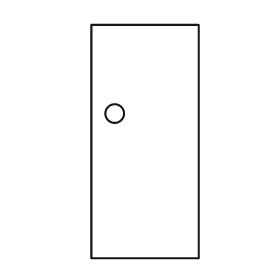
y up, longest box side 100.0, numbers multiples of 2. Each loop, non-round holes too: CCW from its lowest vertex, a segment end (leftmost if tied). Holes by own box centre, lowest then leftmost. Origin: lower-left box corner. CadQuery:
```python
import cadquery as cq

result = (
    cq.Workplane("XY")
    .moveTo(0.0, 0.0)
    .lineTo(46.0, 0.0)
    .lineTo(46.0, 100.0)
    .lineTo(0.0, 100.0)
    .close()
    .moveTo(10.0, 62.0)
    .circle(4.0)
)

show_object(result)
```